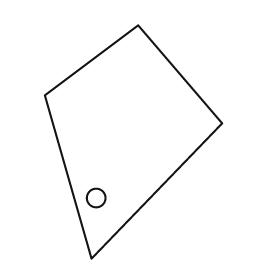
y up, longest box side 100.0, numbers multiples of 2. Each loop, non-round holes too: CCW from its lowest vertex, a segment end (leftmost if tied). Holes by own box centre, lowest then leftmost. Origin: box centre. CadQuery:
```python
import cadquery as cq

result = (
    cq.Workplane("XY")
    .moveTo(-18.0, -50.0)
    .lineTo(38.0, 8.0)
    .lineTo(2.0, 50.0)
    .lineTo(-38.0, 20.0)
    .close()
    .moveTo(-16.0, -24.0)
    .circle(4.0)
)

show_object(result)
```